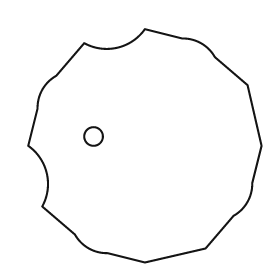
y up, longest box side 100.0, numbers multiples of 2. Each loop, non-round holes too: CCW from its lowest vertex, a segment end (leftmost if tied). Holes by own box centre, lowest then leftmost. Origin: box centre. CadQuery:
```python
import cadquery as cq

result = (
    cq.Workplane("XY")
    .moveTo(0.0, -50.0)
    .lineTo(26.0, -44.0)
    .lineTo(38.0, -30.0)
    .threePointArc((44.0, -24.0), (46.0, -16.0))
    .lineTo(50.0, 0.0)
    .lineTo(44.0, 26.0)
    .lineTo(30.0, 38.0)
    .threePointArc((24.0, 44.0), (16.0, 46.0))
    .lineTo(0.0, 50.0)
    .threePointArc((-12.0, 42.0), (-26.0, 44.0))
    .lineTo(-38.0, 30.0)
    .threePointArc((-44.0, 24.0), (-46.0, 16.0))
    .lineTo(-50.0, 0.0)
    .threePointArc((-42.0, -12.0), (-44.0, -26.0))
    .lineTo(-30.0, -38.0)
    .threePointArc((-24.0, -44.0), (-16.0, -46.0))
    .close()
    .moveTo(-22.0, 4.0)
    .circle(4.0)
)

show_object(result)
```